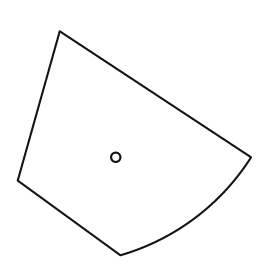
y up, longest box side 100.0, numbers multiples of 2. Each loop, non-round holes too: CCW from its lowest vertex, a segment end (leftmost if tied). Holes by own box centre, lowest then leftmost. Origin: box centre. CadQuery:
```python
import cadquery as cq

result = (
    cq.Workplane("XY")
    .moveTo(-6.0, -48.0)
    .threePointArc((26.0, -32.0), (50.0, -6.0))
    .lineTo(-32.0, 48.0)
    .lineTo(-50.0, -16.0)
    .close()
    .moveTo(-8.0, -6.0)
    .circle(2.0)
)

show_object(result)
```